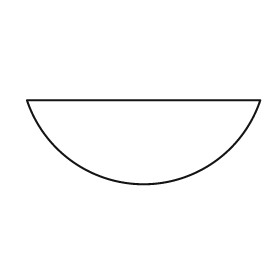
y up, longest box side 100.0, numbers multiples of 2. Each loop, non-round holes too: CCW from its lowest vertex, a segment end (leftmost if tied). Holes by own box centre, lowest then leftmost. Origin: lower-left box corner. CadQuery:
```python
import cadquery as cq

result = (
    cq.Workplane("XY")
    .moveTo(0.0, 36.0)
    .threePointArc((50.0, 0.0), (100.0, 36.0))
    .close()
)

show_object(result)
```